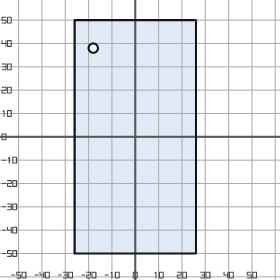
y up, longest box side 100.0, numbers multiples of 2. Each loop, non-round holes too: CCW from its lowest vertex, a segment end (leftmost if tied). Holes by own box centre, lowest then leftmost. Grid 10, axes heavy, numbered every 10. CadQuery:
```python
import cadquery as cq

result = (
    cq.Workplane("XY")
    .moveTo(-26.0, -50.0)
    .lineTo(26.0, -50.0)
    .lineTo(26.0, 50.0)
    .lineTo(-26.0, 50.0)
    .close()
    .moveTo(-18.0, 38.0)
    .circle(2.0)
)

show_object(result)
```